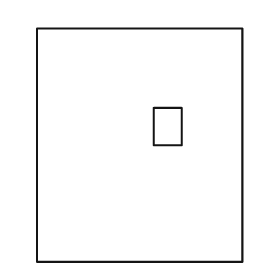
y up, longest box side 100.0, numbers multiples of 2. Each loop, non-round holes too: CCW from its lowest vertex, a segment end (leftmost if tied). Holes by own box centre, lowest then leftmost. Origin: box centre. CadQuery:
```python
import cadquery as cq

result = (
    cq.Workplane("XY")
    .moveTo(-44.0, -50.0)
    .lineTo(44.0, -50.0)
    .lineTo(44.0, 50.0)
    .lineTo(-44.0, 50.0)
    .close()
    .moveTo(6.0, 0.0)
    .lineTo(18.0, 0.0)
    .lineTo(18.0, 16.0)
    .lineTo(6.0, 16.0)
    .close()
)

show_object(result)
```